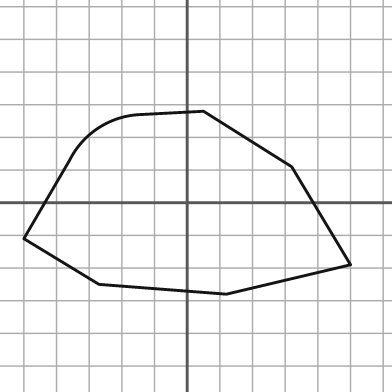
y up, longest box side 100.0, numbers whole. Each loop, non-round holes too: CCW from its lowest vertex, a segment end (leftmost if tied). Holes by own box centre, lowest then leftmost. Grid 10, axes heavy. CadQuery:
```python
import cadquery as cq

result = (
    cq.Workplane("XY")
    .moveTo(12.0, -28.0)
    .lineTo(50.0, -19.0)
    .lineTo(32.0, 11.0)
    .lineTo(5.0, 28.0)
    .lineTo(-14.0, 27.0)
    .threePointArc((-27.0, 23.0), (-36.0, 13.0))
    .lineTo(-50.0, -11.0)
    .lineTo(-27.0, -25.0)
    .close()
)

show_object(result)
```